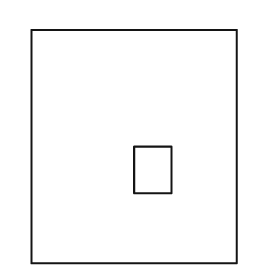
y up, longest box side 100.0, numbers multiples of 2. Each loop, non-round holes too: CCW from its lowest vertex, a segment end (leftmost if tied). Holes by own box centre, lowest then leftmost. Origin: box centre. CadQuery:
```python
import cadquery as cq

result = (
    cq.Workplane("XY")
    .moveTo(-44.0, -50.0)
    .lineTo(44.0, -50.0)
    .lineTo(44.0, 50.0)
    .lineTo(-44.0, 50.0)
    .close()
    .moveTo(0.0, -20.0)
    .lineTo(16.0, -20.0)
    .lineTo(16.0, 0.0)
    .lineTo(0.0, 0.0)
    .close()
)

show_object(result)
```